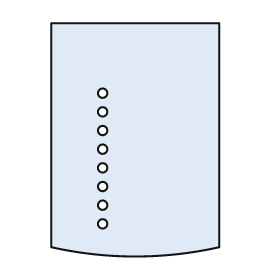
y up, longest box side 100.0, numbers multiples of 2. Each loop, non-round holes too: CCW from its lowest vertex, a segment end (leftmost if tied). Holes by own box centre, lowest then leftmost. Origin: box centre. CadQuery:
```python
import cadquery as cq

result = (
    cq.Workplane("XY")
    .moveTo(-36.0, -46.0)
    .threePointArc((0.0, -50.0), (36.0, -46.0))
    .lineTo(36.0, 50.0)
    .lineTo(-36.0, 50.0)
    .close()
    .moveTo(-14.0, -36.0)
    .circle(2.0)
    .moveTo(-14.0, -28.0)
    .circle(2.0)
    .moveTo(-14.0, -20.0)
    .circle(2.0)
    .moveTo(-14.0, -12.0)
    .circle(2.0)
    .moveTo(-14.0, -4.0)
    .circle(2.0)
    .moveTo(-14.0, 4.0)
    .circle(2.0)
    .moveTo(-14.0, 12.0)
    .circle(2.0)
    .moveTo(-14.0, 20.0)
    .circle(2.0)
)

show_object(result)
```